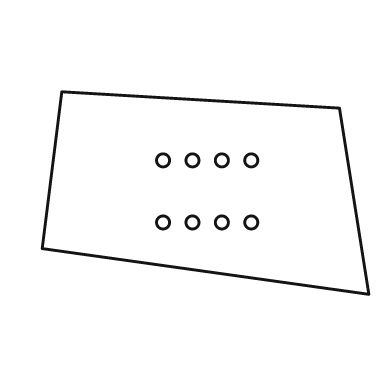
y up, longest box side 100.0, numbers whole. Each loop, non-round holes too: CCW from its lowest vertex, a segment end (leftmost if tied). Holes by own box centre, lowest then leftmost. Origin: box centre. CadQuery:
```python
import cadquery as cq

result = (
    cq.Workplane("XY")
    .moveTo(50.0, -31.0)
    .lineTo(41.0, 26.0)
    .lineTo(-44.0, 31.0)
    .lineTo(-50.0, -17.0)
    .close()
    .moveTo(-13.0, -9.0)
    .circle(2.0)
    .moveTo(-4.0, -9.0)
    .circle(2.0)
    .moveTo(5.0, -9.0)
    .circle(2.0)
    .moveTo(14.0, -9.0)
    .circle(2.0)
    .moveTo(-13.0, 10.0)
    .circle(2.0)
    .moveTo(-4.0, 10.0)
    .circle(2.0)
    .moveTo(5.0, 10.0)
    .circle(2.0)
    .moveTo(14.0, 10.0)
    .circle(2.0)
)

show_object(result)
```